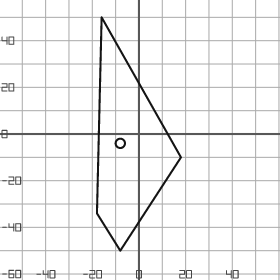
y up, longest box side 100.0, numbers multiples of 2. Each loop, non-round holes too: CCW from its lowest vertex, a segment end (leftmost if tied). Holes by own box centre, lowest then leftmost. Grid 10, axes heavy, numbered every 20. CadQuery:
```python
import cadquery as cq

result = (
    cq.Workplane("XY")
    .moveTo(-8.0, -50.0)
    .lineTo(18.0, -10.0)
    .lineTo(-16.0, 50.0)
    .lineTo(-18.0, -34.0)
    .close()
    .moveTo(-8.0, -4.0)
    .circle(2.0)
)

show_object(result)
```